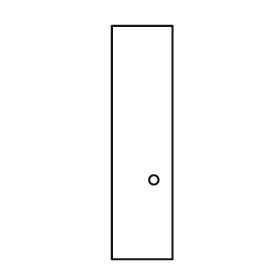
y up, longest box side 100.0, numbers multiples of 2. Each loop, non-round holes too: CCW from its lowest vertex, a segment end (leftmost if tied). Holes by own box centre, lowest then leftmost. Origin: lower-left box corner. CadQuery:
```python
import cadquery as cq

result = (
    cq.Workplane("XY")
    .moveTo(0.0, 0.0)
    .lineTo(26.0, 0.0)
    .lineTo(26.0, 100.0)
    .lineTo(0.0, 100.0)
    .close()
    .moveTo(18.0, 34.0)
    .circle(2.0)
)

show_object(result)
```